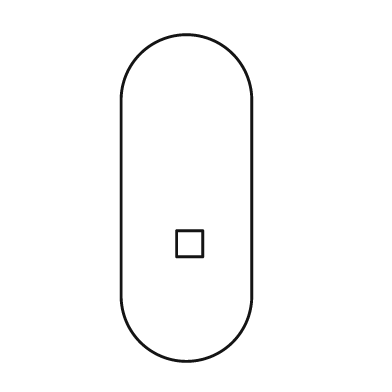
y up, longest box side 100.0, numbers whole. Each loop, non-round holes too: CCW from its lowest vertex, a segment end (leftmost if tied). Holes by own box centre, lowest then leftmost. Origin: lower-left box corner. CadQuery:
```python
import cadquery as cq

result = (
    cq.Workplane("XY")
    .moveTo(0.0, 20.0)
    .threePointArc((20.0, 0.0), (40.0, 20.0))
    .lineTo(40.0, 80.0)
    .threePointArc((20.0, 100.0), (0.0, 80.0))
    .close()
    .moveTo(17.0, 32.0)
    .lineTo(25.0, 32.0)
    .lineTo(25.0, 40.0)
    .lineTo(17.0, 40.0)
    .close()
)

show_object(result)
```